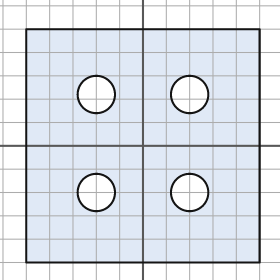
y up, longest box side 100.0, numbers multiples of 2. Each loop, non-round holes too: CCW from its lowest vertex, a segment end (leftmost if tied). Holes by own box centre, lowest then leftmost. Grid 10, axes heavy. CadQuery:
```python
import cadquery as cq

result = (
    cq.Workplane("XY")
    .moveTo(-50.0, -50.0)
    .lineTo(50.0, -50.0)
    .lineTo(50.0, 50.0)
    .lineTo(-50.0, 50.0)
    .close()
    .moveTo(-20.0, -20.0)
    .circle(8.0)
    .moveTo(20.0, -20.0)
    .circle(8.0)
    .moveTo(-20.0, 22.0)
    .circle(8.0)
    .moveTo(20.0, 22.0)
    .circle(8.0)
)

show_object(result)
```